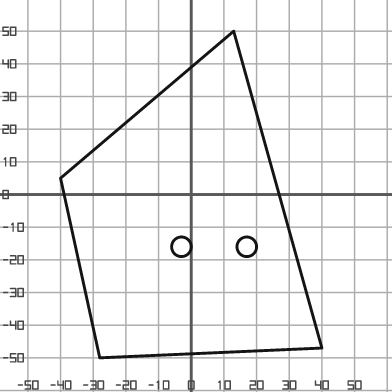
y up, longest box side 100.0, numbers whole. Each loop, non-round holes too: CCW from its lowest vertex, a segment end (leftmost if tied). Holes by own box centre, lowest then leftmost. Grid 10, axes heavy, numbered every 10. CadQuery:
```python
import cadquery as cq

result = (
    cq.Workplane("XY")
    .moveTo(-28.0, -50.0)
    .lineTo(40.0, -47.0)
    .lineTo(13.0, 50.0)
    .lineTo(-40.0, 5.0)
    .close()
    .moveTo(-3.0, -16.0)
    .circle(3.0)
    .moveTo(17.0, -16.0)
    .circle(3.0)
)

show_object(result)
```